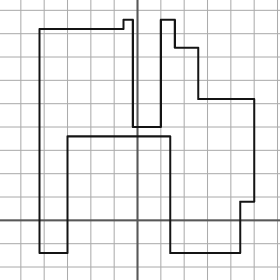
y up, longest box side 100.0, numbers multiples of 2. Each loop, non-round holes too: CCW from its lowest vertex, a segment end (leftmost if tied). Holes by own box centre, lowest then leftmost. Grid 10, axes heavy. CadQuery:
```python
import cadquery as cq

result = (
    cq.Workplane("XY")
    .moveTo(-42.0, -14.0)
    .lineTo(-30.0, -14.0)
    .lineTo(-30.0, 36.0)
    .lineTo(14.0, 36.0)
    .lineTo(14.0, -14.0)
    .lineTo(44.0, -14.0)
    .lineTo(44.0, 8.0)
    .lineTo(50.0, 8.0)
    .lineTo(50.0, 52.0)
    .lineTo(26.0, 52.0)
    .lineTo(26.0, 74.0)
    .lineTo(16.0, 74.0)
    .lineTo(16.0, 86.0)
    .lineTo(10.0, 86.0)
    .lineTo(10.0, 40.0)
    .lineTo(-2.0, 40.0)
    .lineTo(-2.0, 86.0)
    .lineTo(-6.0, 86.0)
    .lineTo(-6.0, 82.0)
    .lineTo(-42.0, 82.0)
    .close()
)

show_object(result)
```